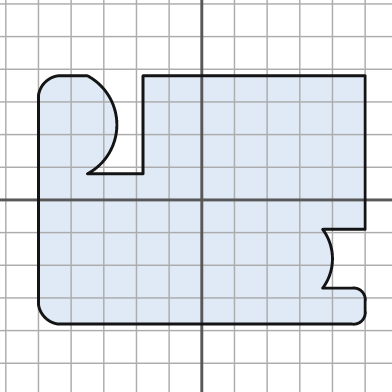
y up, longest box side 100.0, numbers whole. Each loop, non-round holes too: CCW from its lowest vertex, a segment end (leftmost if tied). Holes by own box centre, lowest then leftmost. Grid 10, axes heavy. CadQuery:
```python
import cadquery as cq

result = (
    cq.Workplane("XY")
    .moveTo(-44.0, -38.0)
    .lineTo(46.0, -38.0)
    .threePointArc((49.0, -37.0), (50.0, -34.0))
    .lineTo(50.0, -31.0)
    .threePointArc((49.0, -28.0), (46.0, -27.0))
    .lineTo(37.0, -27.0)
    .threePointArc((40.0, -18.0), (37.0, -9.0))
    .lineTo(50.0, -9.0)
    .lineTo(50.0, 38.0)
    .lineTo(-18.0, 38.0)
    .lineTo(-18.0, 8.0)
    .lineTo(-35.0, 8.0)
    .threePointArc((-26.0, 23.0), (-35.0, 38.0))
    .lineTo(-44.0, 38.0)
    .threePointArc((-48.0, 36.0), (-50.0, 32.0))
    .lineTo(-50.0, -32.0)
    .threePointArc((-48.0, -36.0), (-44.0, -38.0))
    .close()
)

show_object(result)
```